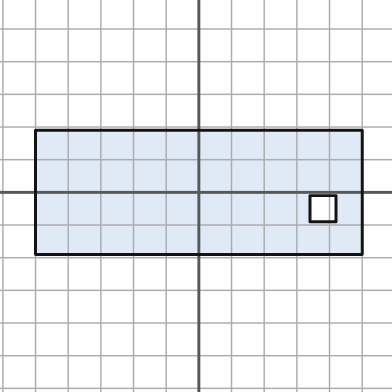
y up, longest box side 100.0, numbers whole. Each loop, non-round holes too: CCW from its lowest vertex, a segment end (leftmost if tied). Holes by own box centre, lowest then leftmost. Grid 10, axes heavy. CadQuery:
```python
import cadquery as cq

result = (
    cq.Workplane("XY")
    .moveTo(-50.0, -19.0)
    .lineTo(50.0, -19.0)
    .lineTo(50.0, 19.0)
    .lineTo(-50.0, 19.0)
    .close()
    .moveTo(34.0, -9.0)
    .lineTo(42.0, -9.0)
    .lineTo(42.0, -1.0)
    .lineTo(34.0, -1.0)
    .close()
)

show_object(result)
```